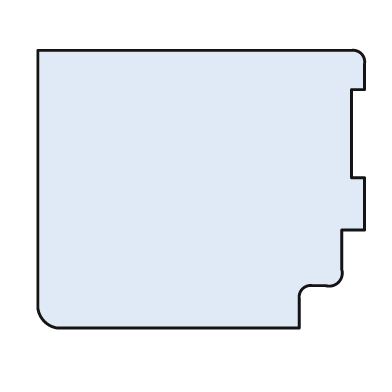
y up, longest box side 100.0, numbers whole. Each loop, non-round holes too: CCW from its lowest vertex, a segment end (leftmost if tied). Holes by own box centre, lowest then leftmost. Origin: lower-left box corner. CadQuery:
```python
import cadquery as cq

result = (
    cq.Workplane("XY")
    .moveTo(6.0, 0.0)
    .lineTo(80.0, 0.0)
    .lineTo(80.0, 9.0)
    .threePointArc((81.0, 12.0), (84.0, 13.0))
    .lineTo(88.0, 13.0)
    .threePointArc((92.0, 14.0), (93.0, 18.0))
    .lineTo(93.0, 30.0)
    .lineTo(100.0, 30.0)
    .lineTo(100.0, 46.0)
    .lineTo(96.0, 46.0)
    .lineTo(96.0, 73.0)
    .lineTo(100.0, 73.0)
    .lineTo(100.0, 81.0)
    .threePointArc((99.0, 84.0), (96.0, 85.0))
    .lineTo(0.0, 85.0)
    .lineTo(0.0, 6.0)
    .threePointArc((2.0, 2.0), (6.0, 0.0))
    .close()
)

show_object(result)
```